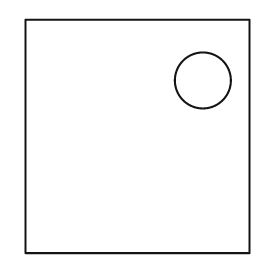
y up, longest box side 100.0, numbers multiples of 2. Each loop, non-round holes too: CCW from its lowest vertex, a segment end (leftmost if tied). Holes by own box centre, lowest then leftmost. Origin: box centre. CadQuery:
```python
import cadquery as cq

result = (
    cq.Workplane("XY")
    .moveTo(-48.0, -50.0)
    .lineTo(48.0, -50.0)
    .lineTo(48.0, 50.0)
    .lineTo(-48.0, 50.0)
    .close()
    .moveTo(28.0, 24.0)
    .circle(12.0)
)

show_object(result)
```